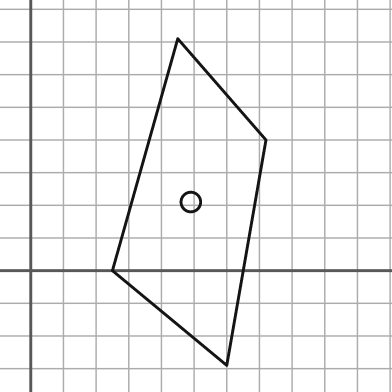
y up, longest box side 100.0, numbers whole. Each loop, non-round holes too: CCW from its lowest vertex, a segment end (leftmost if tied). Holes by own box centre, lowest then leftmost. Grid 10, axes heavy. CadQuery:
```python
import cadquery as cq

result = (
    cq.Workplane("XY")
    .moveTo(60.0, -29.0)
    .lineTo(72.0, 40.0)
    .lineTo(45.0, 71.0)
    .lineTo(25.0, 0.0)
    .close()
    .moveTo(49.0, 21.0)
    .circle(3.0)
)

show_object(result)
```